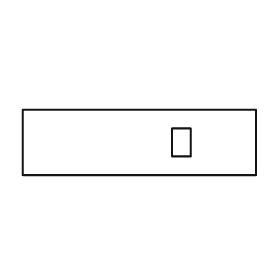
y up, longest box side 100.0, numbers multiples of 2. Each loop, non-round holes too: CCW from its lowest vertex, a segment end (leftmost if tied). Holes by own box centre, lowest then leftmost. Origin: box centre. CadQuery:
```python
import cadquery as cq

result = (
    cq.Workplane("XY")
    .moveTo(-50.0, -14.0)
    .lineTo(50.0, -14.0)
    .lineTo(50.0, 14.0)
    .lineTo(-50.0, 14.0)
    .close()
    .moveTo(14.0, -6.0)
    .lineTo(22.0, -6.0)
    .lineTo(22.0, 6.0)
    .lineTo(14.0, 6.0)
    .close()
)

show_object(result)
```